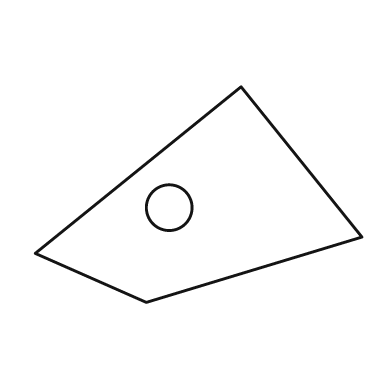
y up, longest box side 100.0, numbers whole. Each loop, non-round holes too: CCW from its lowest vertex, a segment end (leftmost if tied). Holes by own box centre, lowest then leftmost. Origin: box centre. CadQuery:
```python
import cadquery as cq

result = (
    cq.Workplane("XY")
    .moveTo(-16.0, -33.0)
    .lineTo(50.0, -13.0)
    .lineTo(13.0, 33.0)
    .lineTo(-50.0, -18.0)
    .close()
    .moveTo(-9.0, -4.0)
    .circle(7.0)
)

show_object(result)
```